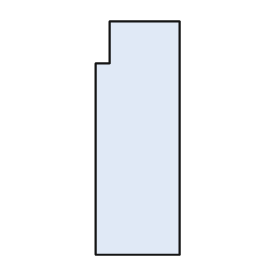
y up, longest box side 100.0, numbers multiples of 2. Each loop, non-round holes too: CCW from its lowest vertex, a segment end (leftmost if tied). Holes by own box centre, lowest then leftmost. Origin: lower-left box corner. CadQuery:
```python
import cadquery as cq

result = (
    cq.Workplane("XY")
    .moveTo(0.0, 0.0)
    .lineTo(36.0, 0.0)
    .lineTo(36.0, 100.0)
    .lineTo(6.0, 100.0)
    .lineTo(6.0, 82.0)
    .lineTo(0.0, 82.0)
    .close()
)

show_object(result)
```